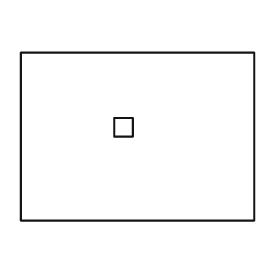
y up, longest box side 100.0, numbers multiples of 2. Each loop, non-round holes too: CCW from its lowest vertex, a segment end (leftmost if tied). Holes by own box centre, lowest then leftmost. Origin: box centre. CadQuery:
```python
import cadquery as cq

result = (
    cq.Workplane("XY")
    .moveTo(-50.0, -36.0)
    .lineTo(50.0, -36.0)
    .lineTo(50.0, 36.0)
    .lineTo(-50.0, 36.0)
    .close()
    .moveTo(-10.0, 0.0)
    .lineTo(-2.0, 0.0)
    .lineTo(-2.0, 8.0)
    .lineTo(-10.0, 8.0)
    .close()
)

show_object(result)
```